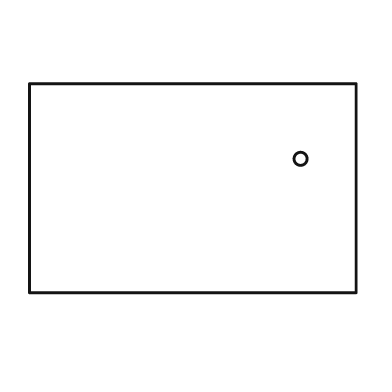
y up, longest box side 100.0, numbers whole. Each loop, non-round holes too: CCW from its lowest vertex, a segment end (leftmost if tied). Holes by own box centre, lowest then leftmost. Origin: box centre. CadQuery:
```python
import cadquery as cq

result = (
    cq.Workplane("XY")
    .moveTo(-50.0, -32.0)
    .lineTo(50.0, -32.0)
    .lineTo(50.0, 32.0)
    .lineTo(-50.0, 32.0)
    .close()
    .moveTo(33.0, 9.0)
    .circle(2.0)
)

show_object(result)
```